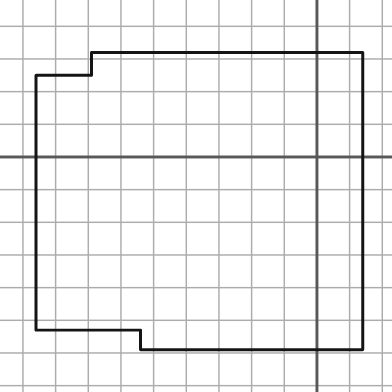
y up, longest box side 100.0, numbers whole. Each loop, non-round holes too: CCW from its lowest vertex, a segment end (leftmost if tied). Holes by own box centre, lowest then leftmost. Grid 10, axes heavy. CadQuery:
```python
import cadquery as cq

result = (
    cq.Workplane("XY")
    .moveTo(-54.0, -59.0)
    .lineTo(14.0, -59.0)
    .lineTo(14.0, 32.0)
    .lineTo(-69.0, 32.0)
    .lineTo(-69.0, 25.0)
    .lineTo(-86.0, 25.0)
    .lineTo(-86.0, -53.0)
    .lineTo(-54.0, -53.0)
    .close()
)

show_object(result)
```